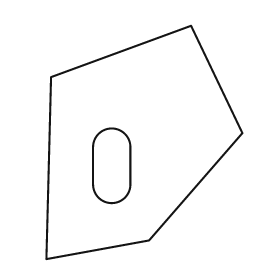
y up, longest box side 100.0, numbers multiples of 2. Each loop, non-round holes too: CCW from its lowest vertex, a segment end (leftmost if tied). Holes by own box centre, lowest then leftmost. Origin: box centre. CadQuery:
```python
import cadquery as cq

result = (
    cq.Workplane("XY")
    .moveTo(-42.0, -50.0)
    .lineTo(2.0, -42.0)
    .lineTo(42.0, 4.0)
    .lineTo(20.0, 50.0)
    .lineTo(-40.0, 28.0)
    .close()
    .moveTo(-22.0, -18.0)
    .threePointArc((-14.0, -26.0), (-6.0, -18.0))
    .lineTo(-6.0, -2.0)
    .threePointArc((-14.0, 6.0), (-22.0, -2.0))
    .close()
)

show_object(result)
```